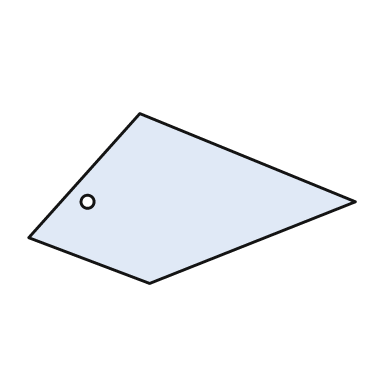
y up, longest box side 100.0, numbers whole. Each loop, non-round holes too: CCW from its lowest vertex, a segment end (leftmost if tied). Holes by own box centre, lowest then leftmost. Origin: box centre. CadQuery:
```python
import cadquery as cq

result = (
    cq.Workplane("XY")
    .moveTo(-13.0, -26.0)
    .lineTo(50.0, -1.0)
    .lineTo(-16.0, 26.0)
    .lineTo(-50.0, -12.0)
    .close()
    .moveTo(-32.0, -1.0)
    .circle(2.0)
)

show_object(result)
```